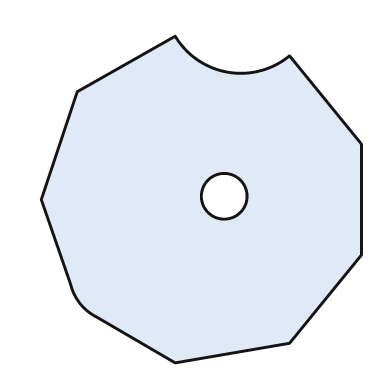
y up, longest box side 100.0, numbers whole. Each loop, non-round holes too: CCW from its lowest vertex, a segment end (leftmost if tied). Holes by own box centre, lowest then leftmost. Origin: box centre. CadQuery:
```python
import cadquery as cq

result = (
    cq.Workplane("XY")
    .moveTo(-8.0, -50.0)
    .lineTo(27.0, -44.0)
    .lineTo(49.0, -17.0)
    .lineTo(49.0, 17.0)
    .lineTo(27.0, 44.0)
    .threePointArc((8.0, 39.0), (-8.0, 50.0))
    .lineTo(-38.0, 33.0)
    .lineTo(-49.0, 0.0)
    .lineTo(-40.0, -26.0)
    .threePointArc((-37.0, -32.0), (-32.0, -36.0))
    .close()
    .moveTo(7.0, 1.0)
    .circle(7.0)
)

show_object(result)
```